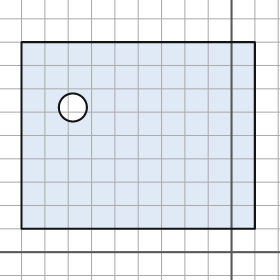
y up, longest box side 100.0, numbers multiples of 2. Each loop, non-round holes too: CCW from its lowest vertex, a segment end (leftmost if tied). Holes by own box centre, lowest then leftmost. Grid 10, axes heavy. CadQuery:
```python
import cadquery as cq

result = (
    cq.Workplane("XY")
    .moveTo(-90.0, 10.0)
    .lineTo(10.0, 10.0)
    .lineTo(10.0, 90.0)
    .lineTo(-90.0, 90.0)
    .close()
    .moveTo(-68.0, 62.0)
    .circle(6.0)
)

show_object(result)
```